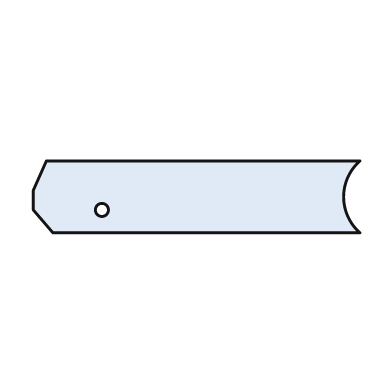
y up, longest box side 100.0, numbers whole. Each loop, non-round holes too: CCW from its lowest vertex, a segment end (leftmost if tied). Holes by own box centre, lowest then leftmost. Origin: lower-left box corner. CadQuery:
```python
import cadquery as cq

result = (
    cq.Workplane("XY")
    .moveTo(6.0, 0.0)
    .lineTo(100.0, 0.0)
    .threePointArc((95.0, 11.0), (100.0, 22.0))
    .lineTo(4.0, 22.0)
    .lineTo(0.0, 13.0)
    .lineTo(0.0, 7.0)
    .close()
    .moveTo(21.0, 7.0)
    .circle(2.0)
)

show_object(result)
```